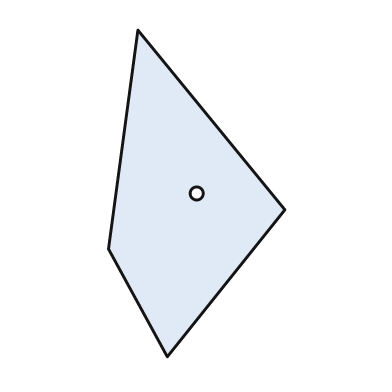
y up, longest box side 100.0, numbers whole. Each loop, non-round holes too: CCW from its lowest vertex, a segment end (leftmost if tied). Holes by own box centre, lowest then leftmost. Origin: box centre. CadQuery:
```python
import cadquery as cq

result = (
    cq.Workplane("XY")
    .moveTo(-9.0, -50.0)
    .lineTo(27.0, -5.0)
    .lineTo(-18.0, 50.0)
    .lineTo(-27.0, -17.0)
    .close()
    .moveTo(0.0, 0.0)
    .circle(2.0)
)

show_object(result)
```